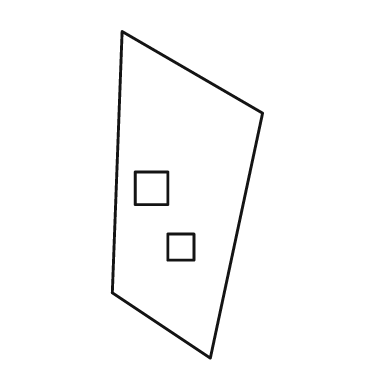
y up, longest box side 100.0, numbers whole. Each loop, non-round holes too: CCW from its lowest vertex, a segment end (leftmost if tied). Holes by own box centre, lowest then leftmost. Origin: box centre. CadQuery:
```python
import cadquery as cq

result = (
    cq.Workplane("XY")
    .moveTo(7.0, -50.0)
    .lineTo(23.0, 25.0)
    .lineTo(-20.0, 50.0)
    .lineTo(-23.0, -30.0)
    .close()
    .moveTo(-6.0, -20.0)
    .lineTo(2.0, -20.0)
    .lineTo(2.0, -12.0)
    .lineTo(-6.0, -12.0)
    .close()
    .moveTo(-16.0, -3.0)
    .lineTo(-6.0, -3.0)
    .lineTo(-6.0, 7.0)
    .lineTo(-16.0, 7.0)
    .close()
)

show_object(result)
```